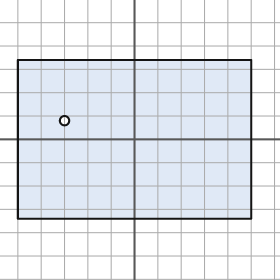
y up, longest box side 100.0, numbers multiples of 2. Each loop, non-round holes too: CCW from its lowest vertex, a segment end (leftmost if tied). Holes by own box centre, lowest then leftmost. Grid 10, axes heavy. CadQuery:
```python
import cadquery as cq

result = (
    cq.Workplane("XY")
    .moveTo(-50.0, -34.0)
    .lineTo(50.0, -34.0)
    .lineTo(50.0, 34.0)
    .lineTo(-50.0, 34.0)
    .close()
    .moveTo(-30.0, 8.0)
    .circle(2.0)
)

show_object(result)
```